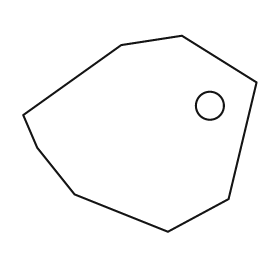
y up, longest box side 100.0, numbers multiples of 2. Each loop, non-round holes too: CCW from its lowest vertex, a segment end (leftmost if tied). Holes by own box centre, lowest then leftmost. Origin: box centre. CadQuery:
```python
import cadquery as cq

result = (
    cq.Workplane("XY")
    .moveTo(12.0, -42.0)
    .lineTo(38.0, -28.0)
    .lineTo(50.0, 22.0)
    .lineTo(18.0, 42.0)
    .lineTo(-8.0, 38.0)
    .lineTo(-50.0, 8.0)
    .lineTo(-44.0, -6.0)
    .lineTo(-28.0, -26.0)
    .close()
    .moveTo(30.0, 12.0)
    .circle(6.0)
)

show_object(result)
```